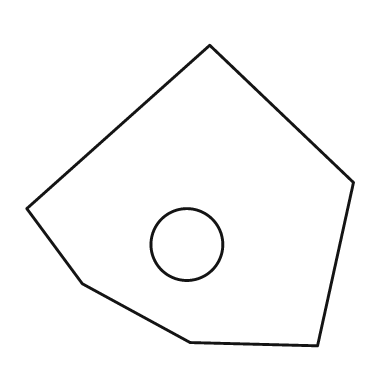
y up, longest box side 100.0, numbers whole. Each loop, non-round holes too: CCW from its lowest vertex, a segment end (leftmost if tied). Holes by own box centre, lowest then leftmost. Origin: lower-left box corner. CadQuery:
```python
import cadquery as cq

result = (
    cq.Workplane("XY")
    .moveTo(89.0, 0.0)
    .lineTo(100.0, 50.0)
    .lineTo(56.0, 92.0)
    .lineTo(0.0, 42.0)
    .lineTo(17.0, 19.0)
    .lineTo(50.0, 1.0)
    .close()
    .moveTo(49.0, 31.0)
    .circle(11.0)
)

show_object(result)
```